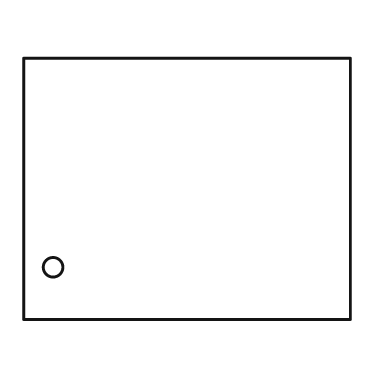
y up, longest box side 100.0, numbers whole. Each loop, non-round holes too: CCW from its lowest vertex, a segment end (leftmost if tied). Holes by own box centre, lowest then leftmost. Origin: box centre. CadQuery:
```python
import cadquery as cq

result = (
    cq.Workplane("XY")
    .moveTo(-50.0, -40.0)
    .lineTo(50.0, -40.0)
    .lineTo(50.0, 40.0)
    .lineTo(-50.0, 40.0)
    .close()
    .moveTo(-41.0, -24.0)
    .circle(3.0)
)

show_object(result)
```